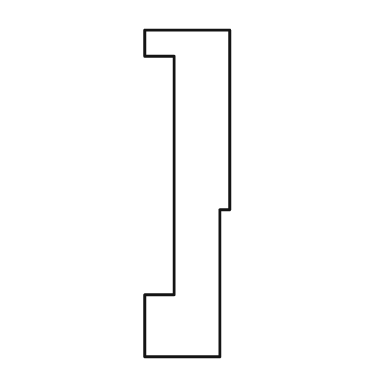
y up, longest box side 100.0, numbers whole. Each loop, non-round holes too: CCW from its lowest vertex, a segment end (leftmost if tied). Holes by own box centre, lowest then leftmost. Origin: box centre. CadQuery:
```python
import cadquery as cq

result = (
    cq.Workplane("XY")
    .moveTo(-13.0, -50.0)
    .lineTo(10.0, -50.0)
    .lineTo(10.0, -5.0)
    .lineTo(13.0, -5.0)
    .lineTo(13.0, 50.0)
    .lineTo(-13.0, 50.0)
    .lineTo(-13.0, 42.0)
    .lineTo(-4.0, 42.0)
    .lineTo(-4.0, -31.0)
    .lineTo(-13.0, -31.0)
    .close()
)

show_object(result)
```